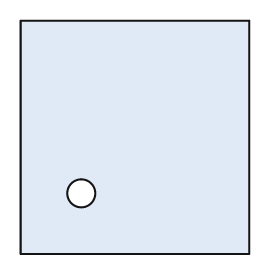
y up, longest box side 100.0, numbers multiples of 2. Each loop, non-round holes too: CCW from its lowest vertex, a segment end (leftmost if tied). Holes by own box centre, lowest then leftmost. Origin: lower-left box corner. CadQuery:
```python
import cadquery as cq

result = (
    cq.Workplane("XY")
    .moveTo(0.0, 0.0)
    .lineTo(98.0, 0.0)
    .lineTo(98.0, 100.0)
    .lineTo(0.0, 100.0)
    .close()
    .moveTo(26.0, 26.0)
    .circle(6.0)
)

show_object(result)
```